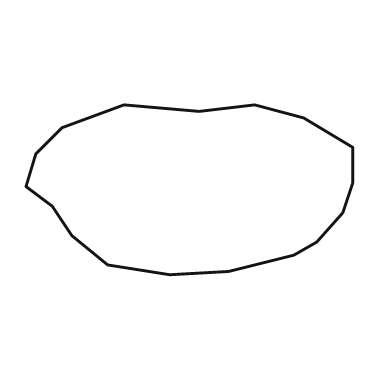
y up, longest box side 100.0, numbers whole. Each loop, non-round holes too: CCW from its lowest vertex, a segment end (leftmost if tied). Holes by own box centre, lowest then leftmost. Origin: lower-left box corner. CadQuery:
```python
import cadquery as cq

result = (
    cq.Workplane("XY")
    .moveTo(44.0, 0.0)
    .lineTo(62.0, 1.0)
    .lineTo(82.0, 6.0)
    .lineTo(89.0, 10.0)
    .lineTo(97.0, 19.0)
    .lineTo(100.0, 28.0)
    .lineTo(100.0, 39.0)
    .lineTo(85.0, 48.0)
    .lineTo(70.0, 52.0)
    .lineTo(53.0, 50.0)
    .lineTo(30.0, 52.0)
    .lineTo(11.0, 45.0)
    .lineTo(3.0, 37.0)
    .lineTo(0.0, 27.0)
    .lineTo(8.0, 21.0)
    .lineTo(14.0, 12.0)
    .lineTo(25.0, 3.0)
    .close()
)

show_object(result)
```